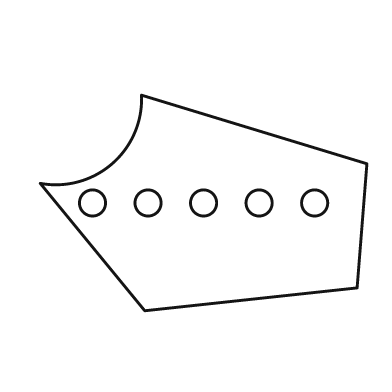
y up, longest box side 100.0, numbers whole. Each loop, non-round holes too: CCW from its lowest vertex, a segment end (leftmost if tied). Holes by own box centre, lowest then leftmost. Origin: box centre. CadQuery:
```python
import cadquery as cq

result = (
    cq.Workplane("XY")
    .moveTo(-18.0, -33.0)
    .lineTo(47.0, -26.0)
    .lineTo(50.0, 12.0)
    .lineTo(-19.0, 33.0)
    .threePointArc((-28.0, 12.0), (-50.0, 6.0))
    .close()
    .moveTo(-34.0, 0.0)
    .circle(4.0)
    .moveTo(-17.0, 0.0)
    .circle(4.0)
    .moveTo(0.0, 0.0)
    .circle(4.0)
    .moveTo(17.0, 0.0)
    .circle(4.0)
    .moveTo(34.0, 0.0)
    .circle(4.0)
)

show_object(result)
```